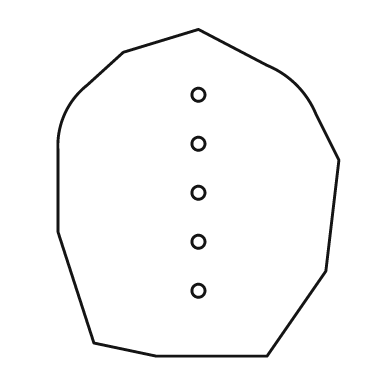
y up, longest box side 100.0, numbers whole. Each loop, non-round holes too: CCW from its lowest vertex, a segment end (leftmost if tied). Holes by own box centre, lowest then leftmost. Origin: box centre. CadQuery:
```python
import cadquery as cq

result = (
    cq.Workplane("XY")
    .moveTo(-13.0, -50.0)
    .lineTo(21.0, -50.0)
    .lineTo(39.0, -24.0)
    .lineTo(43.0, 10.0)
    .lineTo(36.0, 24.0)
    .threePointArc((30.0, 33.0), (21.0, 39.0))
    .lineTo(0.0, 50.0)
    .lineTo(-23.0, 43.0)
    .lineTo(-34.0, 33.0)
    .threePointArc((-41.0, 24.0), (-43.0, 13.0))
    .lineTo(-43.0, -12.0)
    .lineTo(-32.0, -46.0)
    .close()
    .moveTo(0.0, -30.0)
    .circle(2.0)
    .moveTo(0.0, -15.0)
    .circle(2.0)
    .moveTo(0.0, 0.0)
    .circle(2.0)
    .moveTo(0.0, 15.0)
    .circle(2.0)
    .moveTo(0.0, 30.0)
    .circle(2.0)
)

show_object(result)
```